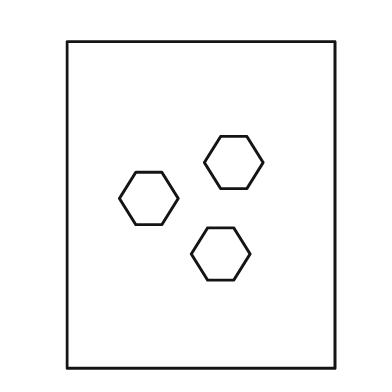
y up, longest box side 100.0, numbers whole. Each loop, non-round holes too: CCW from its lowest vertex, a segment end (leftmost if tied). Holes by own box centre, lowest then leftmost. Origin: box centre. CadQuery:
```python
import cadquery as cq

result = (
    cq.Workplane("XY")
    .moveTo(-41.0, -50.0)
    .lineTo(41.0, -50.0)
    .lineTo(41.0, 50.0)
    .lineTo(-41.0, 50.0)
    .close()
    .moveTo(2.0, -23.0)
    .lineTo(10.0, -23.0)
    .lineTo(15.0, -15.0)
    .lineTo(10.0, -7.0)
    .lineTo(2.0, -7.0)
    .lineTo(-3.0, -15.0)
    .close()
    .moveTo(-20.0, -6.0)
    .lineTo(-12.0, -6.0)
    .lineTo(-7.0, 2.0)
    .lineTo(-12.0, 10.0)
    .lineTo(-20.0, 10.0)
    .lineTo(-25.0, 2.0)
    .close()
    .moveTo(6.0, 5.0)
    .lineTo(14.0, 5.0)
    .lineTo(19.0, 13.0)
    .lineTo(14.0, 21.0)
    .lineTo(6.0, 21.0)
    .lineTo(1.0, 13.0)
    .close()
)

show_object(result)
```